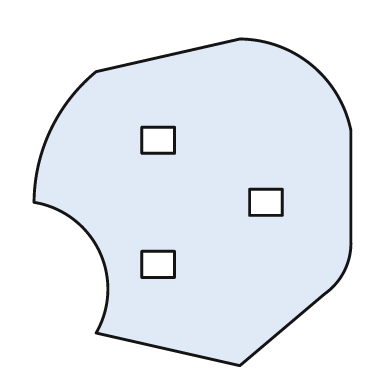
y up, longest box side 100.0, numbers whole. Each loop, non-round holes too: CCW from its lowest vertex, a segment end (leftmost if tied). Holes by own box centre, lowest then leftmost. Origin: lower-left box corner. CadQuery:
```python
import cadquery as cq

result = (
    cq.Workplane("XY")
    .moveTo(63.0, 0.0)
    .lineTo(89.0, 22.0)
    .threePointArc((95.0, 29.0), (97.0, 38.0))
    .lineTo(97.0, 72.0)
    .threePointArc((85.0, 92.0), (63.0, 100.0))
    .lineTo(19.0, 90.0)
    .threePointArc((5.0, 72.0), (0.0, 50.0))
    .threePointArc((20.0, 35.0), (19.0, 10.0))
    .close()
    .moveTo(33.0, 27.0)
    .lineTo(43.0, 27.0)
    .lineTo(43.0, 35.0)
    .lineTo(33.0, 35.0)
    .close()
    .moveTo(66.0, 46.0)
    .lineTo(76.0, 46.0)
    .lineTo(76.0, 54.0)
    .lineTo(66.0, 54.0)
    .close()
    .moveTo(33.0, 65.0)
    .lineTo(43.0, 65.0)
    .lineTo(43.0, 73.0)
    .lineTo(33.0, 73.0)
    .close()
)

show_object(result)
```